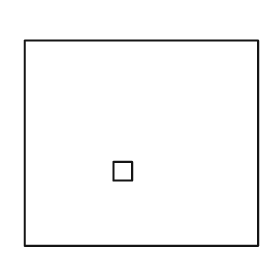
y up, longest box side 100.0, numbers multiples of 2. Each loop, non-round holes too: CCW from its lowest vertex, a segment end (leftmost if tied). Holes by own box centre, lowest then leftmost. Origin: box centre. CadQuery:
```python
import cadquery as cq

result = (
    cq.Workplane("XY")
    .moveTo(-50.0, -44.0)
    .lineTo(50.0, -44.0)
    .lineTo(50.0, 44.0)
    .lineTo(-50.0, 44.0)
    .close()
    .moveTo(-12.0, -16.0)
    .lineTo(-4.0, -16.0)
    .lineTo(-4.0, -8.0)
    .lineTo(-12.0, -8.0)
    .close()
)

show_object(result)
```